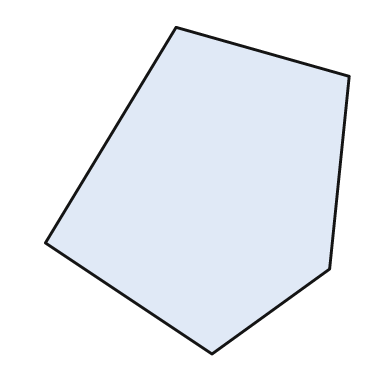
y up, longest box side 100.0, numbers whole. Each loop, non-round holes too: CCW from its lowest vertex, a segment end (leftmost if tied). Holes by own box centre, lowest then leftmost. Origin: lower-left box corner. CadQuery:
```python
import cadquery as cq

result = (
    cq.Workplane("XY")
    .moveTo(51.0, 0.0)
    .lineTo(87.0, 26.0)
    .lineTo(93.0, 85.0)
    .lineTo(40.0, 100.0)
    .lineTo(0.0, 34.0)
    .close()
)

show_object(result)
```